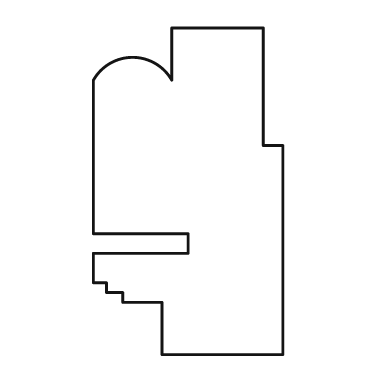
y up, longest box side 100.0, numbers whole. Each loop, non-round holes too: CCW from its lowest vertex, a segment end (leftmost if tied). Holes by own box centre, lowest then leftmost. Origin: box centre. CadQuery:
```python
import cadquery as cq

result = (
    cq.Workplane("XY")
    .moveTo(-8.0, -50.0)
    .lineTo(29.0, -50.0)
    .lineTo(29.0, 14.0)
    .lineTo(23.0, 14.0)
    .lineTo(23.0, 50.0)
    .lineTo(-5.0, 50.0)
    .lineTo(-5.0, 34.0)
    .threePointArc((-17.0, 41.0), (-29.0, 34.0))
    .lineTo(-29.0, -13.0)
    .lineTo(0.0, -13.0)
    .lineTo(0.0, -19.0)
    .lineTo(-29.0, -19.0)
    .lineTo(-29.0, -28.0)
    .lineTo(-25.0, -28.0)
    .lineTo(-25.0, -31.0)
    .lineTo(-20.0, -31.0)
    .lineTo(-20.0, -34.0)
    .lineTo(-8.0, -34.0)
    .close()
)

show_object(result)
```